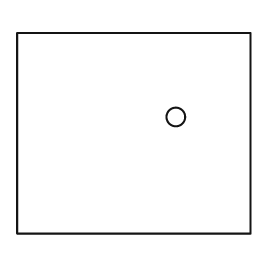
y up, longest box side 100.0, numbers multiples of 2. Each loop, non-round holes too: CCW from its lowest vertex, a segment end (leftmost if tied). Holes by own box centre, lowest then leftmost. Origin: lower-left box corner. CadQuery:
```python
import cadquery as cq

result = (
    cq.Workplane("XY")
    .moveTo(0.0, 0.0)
    .lineTo(100.0, 0.0)
    .lineTo(100.0, 86.0)
    .lineTo(0.0, 86.0)
    .close()
    .moveTo(68.0, 50.0)
    .circle(4.0)
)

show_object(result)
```